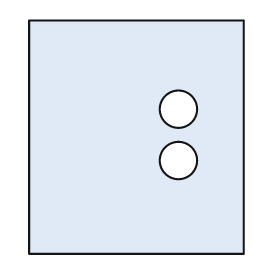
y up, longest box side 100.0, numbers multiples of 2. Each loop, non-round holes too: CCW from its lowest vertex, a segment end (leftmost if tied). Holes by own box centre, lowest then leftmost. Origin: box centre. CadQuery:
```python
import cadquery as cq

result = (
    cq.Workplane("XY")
    .moveTo(-46.0, -50.0)
    .lineTo(46.0, -50.0)
    .lineTo(46.0, 50.0)
    .lineTo(-46.0, 50.0)
    .close()
    .moveTo(18.0, -10.0)
    .circle(8.0)
    .moveTo(18.0, 12.0)
    .circle(8.0)
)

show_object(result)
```